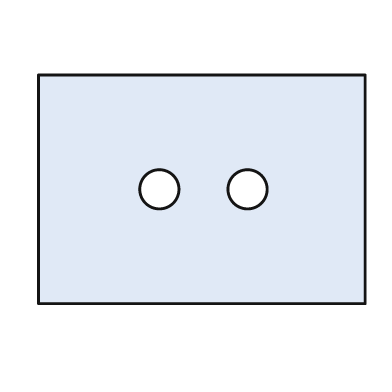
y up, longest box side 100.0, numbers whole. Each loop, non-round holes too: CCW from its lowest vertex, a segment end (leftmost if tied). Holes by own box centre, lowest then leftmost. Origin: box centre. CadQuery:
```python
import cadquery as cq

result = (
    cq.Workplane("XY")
    .moveTo(-50.0, -35.0)
    .lineTo(50.0, -35.0)
    .lineTo(50.0, 35.0)
    .lineTo(-50.0, 35.0)
    .close()
    .moveTo(-13.0, 0.0)
    .circle(6.0)
    .moveTo(14.0, 0.0)
    .circle(6.0)
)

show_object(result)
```